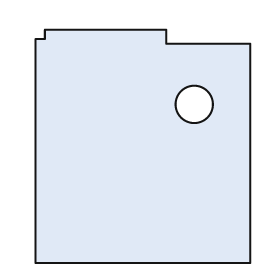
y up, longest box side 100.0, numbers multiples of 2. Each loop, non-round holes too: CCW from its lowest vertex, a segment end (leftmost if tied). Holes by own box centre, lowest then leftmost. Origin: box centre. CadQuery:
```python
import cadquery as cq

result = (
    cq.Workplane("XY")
    .moveTo(-46.0, -50.0)
    .lineTo(46.0, -50.0)
    .lineTo(46.0, 44.0)
    .lineTo(10.0, 44.0)
    .lineTo(10.0, 50.0)
    .lineTo(-42.0, 50.0)
    .lineTo(-42.0, 46.0)
    .lineTo(-46.0, 46.0)
    .close()
    .moveTo(22.0, 18.0)
    .circle(8.0)
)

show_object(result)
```